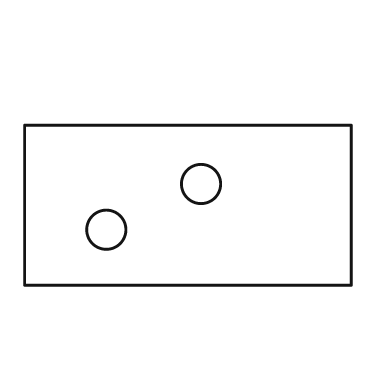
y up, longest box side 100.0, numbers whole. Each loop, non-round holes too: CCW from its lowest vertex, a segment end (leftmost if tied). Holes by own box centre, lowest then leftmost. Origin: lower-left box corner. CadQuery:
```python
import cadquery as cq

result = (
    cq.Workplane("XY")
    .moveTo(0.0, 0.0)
    .lineTo(100.0, 0.0)
    .lineTo(100.0, 49.0)
    .lineTo(0.0, 49.0)
    .close()
    .moveTo(25.0, 17.0)
    .circle(6.0)
    .moveTo(54.0, 31.0)
    .circle(6.0)
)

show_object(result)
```